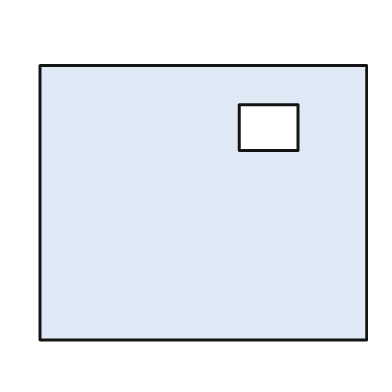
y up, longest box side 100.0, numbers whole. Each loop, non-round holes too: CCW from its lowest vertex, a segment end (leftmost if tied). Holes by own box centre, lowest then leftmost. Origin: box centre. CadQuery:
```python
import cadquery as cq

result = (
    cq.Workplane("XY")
    .moveTo(-50.0, -42.0)
    .lineTo(50.0, -42.0)
    .lineTo(50.0, 42.0)
    .lineTo(-50.0, 42.0)
    .close()
    .moveTo(11.0, 16.0)
    .lineTo(29.0, 16.0)
    .lineTo(29.0, 30.0)
    .lineTo(11.0, 30.0)
    .close()
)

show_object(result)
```